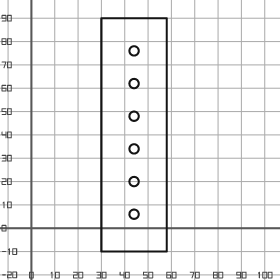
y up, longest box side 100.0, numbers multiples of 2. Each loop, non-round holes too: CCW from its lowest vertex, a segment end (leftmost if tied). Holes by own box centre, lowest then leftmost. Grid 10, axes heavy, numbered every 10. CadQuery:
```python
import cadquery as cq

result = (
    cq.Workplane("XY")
    .moveTo(30.0, -10.0)
    .lineTo(58.0, -10.0)
    .lineTo(58.0, 90.0)
    .lineTo(30.0, 90.0)
    .close()
    .moveTo(44.0, 6.0)
    .circle(2.0)
    .moveTo(44.0, 20.0)
    .circle(2.0)
    .moveTo(44.0, 34.0)
    .circle(2.0)
    .moveTo(44.0, 48.0)
    .circle(2.0)
    .moveTo(44.0, 62.0)
    .circle(2.0)
    .moveTo(44.0, 76.0)
    .circle(2.0)
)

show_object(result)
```